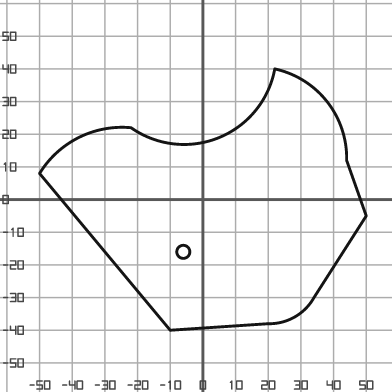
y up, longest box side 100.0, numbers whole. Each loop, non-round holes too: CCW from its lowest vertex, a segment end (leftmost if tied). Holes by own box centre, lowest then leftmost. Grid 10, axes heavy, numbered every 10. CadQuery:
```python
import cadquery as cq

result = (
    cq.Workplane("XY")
    .moveTo(-10.0, -40.0)
    .lineTo(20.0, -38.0)
    .threePointArc((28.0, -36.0), (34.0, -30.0))
    .lineTo(50.0, -5.0)
    .lineTo(44.0, 12.0)
    .threePointArc((38.0, 30.0), (22.0, 40.0))
    .threePointArc((5.0, 19.0), (-22.0, 22.0))
    .threePointArc((-38.0, 19.0), (-50.0, 8.0))
    .close()
    .moveTo(-6.0, -16.0)
    .circle(2.0)
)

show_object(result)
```